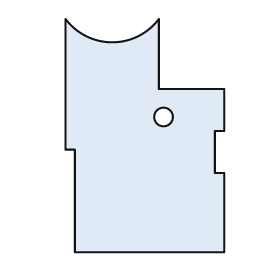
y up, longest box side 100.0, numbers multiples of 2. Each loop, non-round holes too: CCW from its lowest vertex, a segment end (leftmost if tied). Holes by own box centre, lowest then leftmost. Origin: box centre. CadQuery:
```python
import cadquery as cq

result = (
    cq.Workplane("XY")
    .moveTo(-30.0, -50.0)
    .lineTo(34.0, -50.0)
    .lineTo(34.0, -16.0)
    .lineTo(30.0, -16.0)
    .lineTo(30.0, 2.0)
    .lineTo(34.0, 2.0)
    .lineTo(34.0, 20.0)
    .lineTo(6.0, 20.0)
    .lineTo(6.0, 50.0)
    .threePointArc((-14.0, 40.0), (-34.0, 50.0))
    .lineTo(-34.0, -6.0)
    .lineTo(-30.0, -6.0)
    .close()
    .moveTo(8.0, 8.0)
    .circle(4.0)
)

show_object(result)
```